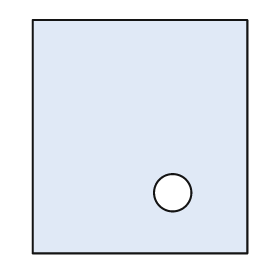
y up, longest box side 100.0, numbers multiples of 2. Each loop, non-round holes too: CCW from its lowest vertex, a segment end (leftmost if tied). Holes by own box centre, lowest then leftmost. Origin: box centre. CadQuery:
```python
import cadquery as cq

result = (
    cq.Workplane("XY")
    .moveTo(-46.0, -50.0)
    .lineTo(46.0, -50.0)
    .lineTo(46.0, 50.0)
    .lineTo(-46.0, 50.0)
    .close()
    .moveTo(14.0, -24.0)
    .circle(8.0)
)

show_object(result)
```